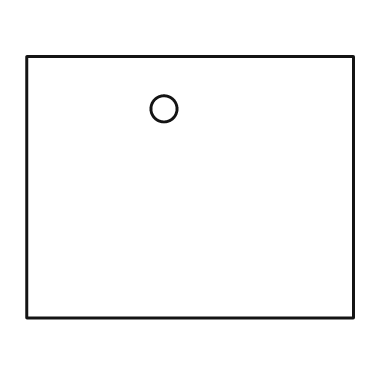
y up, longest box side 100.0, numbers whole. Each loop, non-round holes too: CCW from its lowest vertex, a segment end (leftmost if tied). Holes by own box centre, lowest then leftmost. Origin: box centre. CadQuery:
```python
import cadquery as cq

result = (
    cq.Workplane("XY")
    .moveTo(-50.0, -40.0)
    .lineTo(50.0, -40.0)
    .lineTo(50.0, 40.0)
    .lineTo(-50.0, 40.0)
    .close()
    .moveTo(-8.0, 24.0)
    .circle(4.0)
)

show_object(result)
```